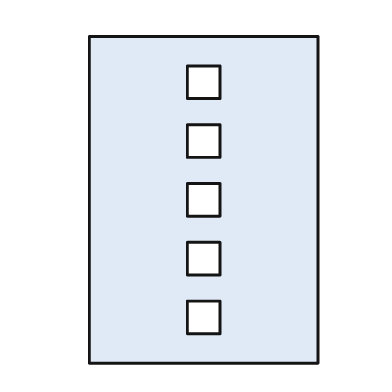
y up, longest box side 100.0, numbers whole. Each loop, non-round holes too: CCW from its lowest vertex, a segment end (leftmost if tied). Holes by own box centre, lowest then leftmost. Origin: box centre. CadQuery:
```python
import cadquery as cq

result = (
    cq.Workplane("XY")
    .moveTo(-35.0, -50.0)
    .lineTo(35.0, -50.0)
    .lineTo(35.0, 50.0)
    .lineTo(-35.0, 50.0)
    .close()
    .moveTo(-5.0, -41.0)
    .lineTo(5.0, -41.0)
    .lineTo(5.0, -31.0)
    .lineTo(-5.0, -31.0)
    .close()
    .moveTo(-5.0, -23.0)
    .lineTo(5.0, -23.0)
    .lineTo(5.0, -13.0)
    .lineTo(-5.0, -13.0)
    .close()
    .moveTo(-5.0, -5.0)
    .lineTo(5.0, -5.0)
    .lineTo(5.0, 5.0)
    .lineTo(-5.0, 5.0)
    .close()
    .moveTo(-5.0, 13.0)
    .lineTo(5.0, 13.0)
    .lineTo(5.0, 23.0)
    .lineTo(-5.0, 23.0)
    .close()
    .moveTo(-5.0, 31.0)
    .lineTo(5.0, 31.0)
    .lineTo(5.0, 41.0)
    .lineTo(-5.0, 41.0)
    .close()
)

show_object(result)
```